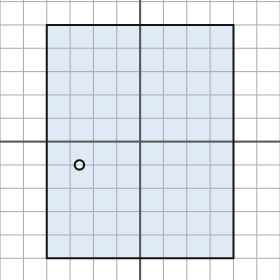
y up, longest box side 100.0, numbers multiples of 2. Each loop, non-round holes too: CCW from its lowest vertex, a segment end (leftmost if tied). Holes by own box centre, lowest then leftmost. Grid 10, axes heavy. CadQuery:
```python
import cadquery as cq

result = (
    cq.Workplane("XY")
    .moveTo(-40.0, -50.0)
    .lineTo(40.0, -50.0)
    .lineTo(40.0, 50.0)
    .lineTo(-40.0, 50.0)
    .close()
    .moveTo(-26.0, -10.0)
    .circle(2.0)
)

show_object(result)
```